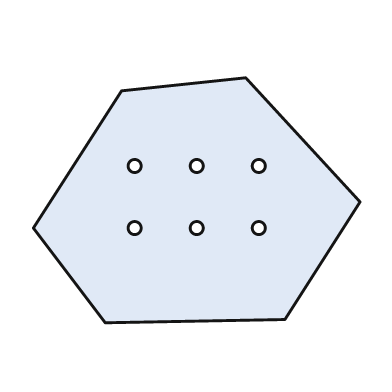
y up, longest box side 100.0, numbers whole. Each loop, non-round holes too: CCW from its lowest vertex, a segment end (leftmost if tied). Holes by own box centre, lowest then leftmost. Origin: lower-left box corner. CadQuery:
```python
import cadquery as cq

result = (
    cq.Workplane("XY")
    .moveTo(22.0, 0.0)
    .lineTo(77.0, 1.0)
    .lineTo(100.0, 37.0)
    .lineTo(65.0, 75.0)
    .lineTo(27.0, 71.0)
    .lineTo(0.0, 29.0)
    .close()
    .moveTo(31.0, 29.0)
    .circle(2.0)
    .moveTo(50.0, 29.0)
    .circle(2.0)
    .moveTo(69.0, 29.0)
    .circle(2.0)
    .moveTo(31.0, 48.0)
    .circle(2.0)
    .moveTo(50.0, 48.0)
    .circle(2.0)
    .moveTo(69.0, 48.0)
    .circle(2.0)
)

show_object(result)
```